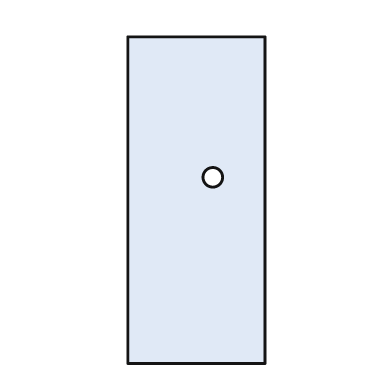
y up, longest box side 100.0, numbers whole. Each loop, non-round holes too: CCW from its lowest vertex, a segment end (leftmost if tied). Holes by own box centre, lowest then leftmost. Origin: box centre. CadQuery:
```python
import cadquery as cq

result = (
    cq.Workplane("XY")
    .moveTo(-21.0, -50.0)
    .lineTo(21.0, -50.0)
    .lineTo(21.0, 50.0)
    .lineTo(-21.0, 50.0)
    .close()
    .moveTo(5.0, 7.0)
    .circle(3.0)
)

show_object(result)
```